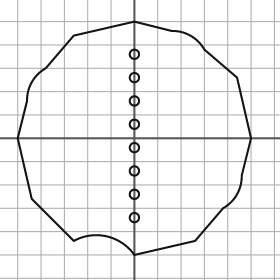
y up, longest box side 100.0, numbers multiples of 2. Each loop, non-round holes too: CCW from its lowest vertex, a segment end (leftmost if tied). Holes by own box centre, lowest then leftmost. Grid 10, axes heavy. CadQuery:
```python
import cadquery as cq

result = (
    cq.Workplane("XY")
    .moveTo(0.0, -50.0)
    .lineTo(26.0, -44.0)
    .lineTo(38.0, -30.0)
    .threePointArc((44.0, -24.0), (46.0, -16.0))
    .lineTo(50.0, 0.0)
    .lineTo(44.0, 26.0)
    .lineTo(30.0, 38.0)
    .threePointArc((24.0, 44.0), (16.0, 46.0))
    .lineTo(0.0, 50.0)
    .lineTo(-26.0, 44.0)
    .lineTo(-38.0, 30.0)
    .threePointArc((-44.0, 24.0), (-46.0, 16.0))
    .lineTo(-50.0, 0.0)
    .lineTo(-44.0, -26.0)
    .lineTo(-26.0, -44.0)
    .threePointArc((-12.0, -42.0), (0.0, -50.0))
    .close()
    .moveTo(0.0, -34.0)
    .circle(2.0)
    .moveTo(0.0, -24.0)
    .circle(2.0)
    .moveTo(0.0, -14.0)
    .circle(2.0)
    .moveTo(0.0, -4.0)
    .circle(2.0)
    .moveTo(0.0, 6.0)
    .circle(2.0)
    .moveTo(0.0, 16.0)
    .circle(2.0)
    .moveTo(0.0, 26.0)
    .circle(2.0)
    .moveTo(0.0, 36.0)
    .circle(2.0)
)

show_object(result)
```